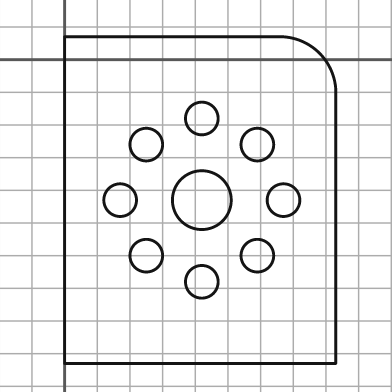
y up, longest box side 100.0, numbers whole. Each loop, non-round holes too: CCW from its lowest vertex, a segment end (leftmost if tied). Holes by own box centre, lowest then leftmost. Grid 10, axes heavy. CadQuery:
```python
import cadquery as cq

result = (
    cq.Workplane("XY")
    .moveTo(0.0, -93.0)
    .lineTo(83.0, -93.0)
    .lineTo(83.0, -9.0)
    .threePointArc((78.0, 2.0), (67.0, 7.0))
    .lineTo(0.0, 7.0)
    .close()
    .moveTo(42.0, -68.0)
    .circle(5.0)
    .moveTo(25.0, -60.0)
    .circle(5.0)
    .moveTo(59.0, -60.0)
    .circle(5.0)
    .moveTo(17.0, -43.0)
    .circle(5.0)
    .moveTo(42.0, -43.0)
    .circle(9.0)
    .moveTo(67.0, -43.0)
    .circle(5.0)
    .moveTo(25.0, -26.0)
    .circle(5.0)
    .moveTo(59.0, -26.0)
    .circle(5.0)
    .moveTo(42.0, -18.0)
    .circle(5.0)
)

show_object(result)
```